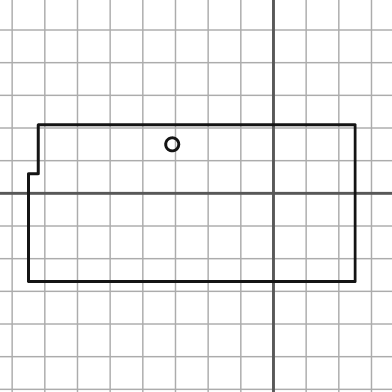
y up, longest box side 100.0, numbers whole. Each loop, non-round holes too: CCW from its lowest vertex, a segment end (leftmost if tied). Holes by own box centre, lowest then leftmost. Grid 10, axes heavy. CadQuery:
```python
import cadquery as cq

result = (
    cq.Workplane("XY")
    .moveTo(-75.0, -27.0)
    .lineTo(25.0, -27.0)
    .lineTo(25.0, 21.0)
    .lineTo(-72.0, 21.0)
    .lineTo(-72.0, 6.0)
    .lineTo(-75.0, 6.0)
    .close()
    .moveTo(-31.0, 15.0)
    .circle(2.0)
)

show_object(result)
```